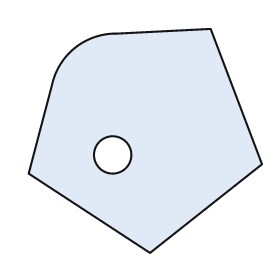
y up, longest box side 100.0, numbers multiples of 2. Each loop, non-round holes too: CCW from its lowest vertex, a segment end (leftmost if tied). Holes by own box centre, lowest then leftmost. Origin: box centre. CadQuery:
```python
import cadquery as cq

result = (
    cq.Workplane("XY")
    .moveTo(2.0, -48.0)
    .lineTo(50.0, -10.0)
    .lineTo(28.0, 48.0)
    .lineTo(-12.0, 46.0)
    .threePointArc((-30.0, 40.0), (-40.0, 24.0))
    .lineTo(-50.0, -14.0)
    .close()
    .moveTo(-14.0, -6.0)
    .circle(8.0)
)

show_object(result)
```